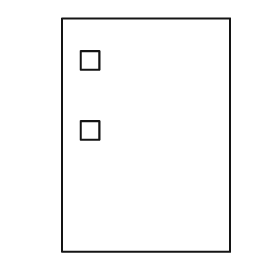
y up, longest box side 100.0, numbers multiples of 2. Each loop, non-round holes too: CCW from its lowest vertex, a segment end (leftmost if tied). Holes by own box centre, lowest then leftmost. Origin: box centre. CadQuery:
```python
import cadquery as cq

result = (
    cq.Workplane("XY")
    .moveTo(-36.0, -50.0)
    .lineTo(36.0, -50.0)
    .lineTo(36.0, 50.0)
    .lineTo(-36.0, 50.0)
    .close()
    .moveTo(-28.0, -2.0)
    .lineTo(-20.0, -2.0)
    .lineTo(-20.0, 6.0)
    .lineTo(-28.0, 6.0)
    .close()
    .moveTo(-28.0, 28.0)
    .lineTo(-20.0, 28.0)
    .lineTo(-20.0, 36.0)
    .lineTo(-28.0, 36.0)
    .close()
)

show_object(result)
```